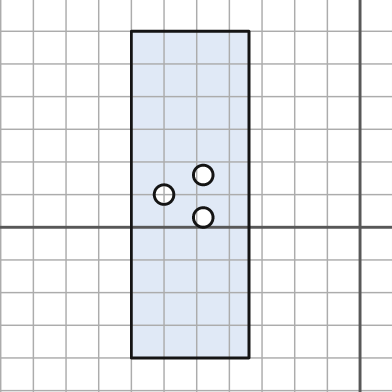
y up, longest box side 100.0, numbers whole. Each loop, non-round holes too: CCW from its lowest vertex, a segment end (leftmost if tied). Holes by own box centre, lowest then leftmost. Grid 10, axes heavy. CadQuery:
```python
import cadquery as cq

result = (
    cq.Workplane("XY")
    .moveTo(-70.0, -40.0)
    .lineTo(-34.0, -40.0)
    .lineTo(-34.0, 60.0)
    .lineTo(-70.0, 60.0)
    .close()
    .moveTo(-48.0, 3.0)
    .circle(3.0)
    .moveTo(-60.0, 10.0)
    .circle(3.0)
    .moveTo(-48.0, 16.0)
    .circle(3.0)
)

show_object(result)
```